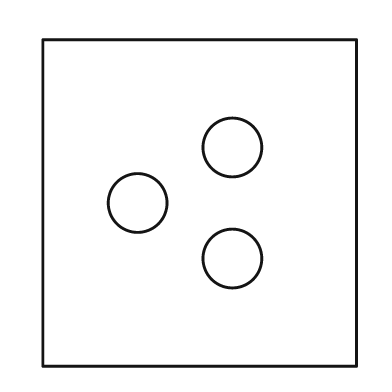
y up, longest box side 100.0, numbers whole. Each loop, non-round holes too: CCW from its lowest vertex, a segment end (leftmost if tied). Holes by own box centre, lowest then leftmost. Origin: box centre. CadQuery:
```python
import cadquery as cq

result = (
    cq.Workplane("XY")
    .moveTo(-48.0, -50.0)
    .lineTo(48.0, -50.0)
    .lineTo(48.0, 50.0)
    .lineTo(-48.0, 50.0)
    .close()
    .moveTo(10.0, -17.0)
    .circle(9.0)
    .moveTo(-19.0, 0.0)
    .circle(9.0)
    .moveTo(10.0, 17.0)
    .circle(9.0)
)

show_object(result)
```